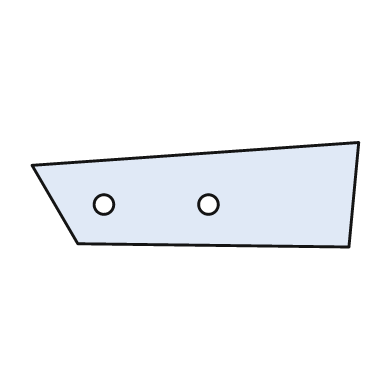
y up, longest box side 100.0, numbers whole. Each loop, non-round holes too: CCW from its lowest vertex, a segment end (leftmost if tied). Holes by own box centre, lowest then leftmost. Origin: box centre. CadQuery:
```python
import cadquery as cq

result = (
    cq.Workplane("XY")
    .moveTo(47.0, -16.0)
    .lineTo(50.0, 16.0)
    .lineTo(-50.0, 9.0)
    .lineTo(-36.0, -15.0)
    .close()
    .moveTo(-28.0, -3.0)
    .circle(3.0)
    .moveTo(4.0, -3.0)
    .circle(3.0)
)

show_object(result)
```